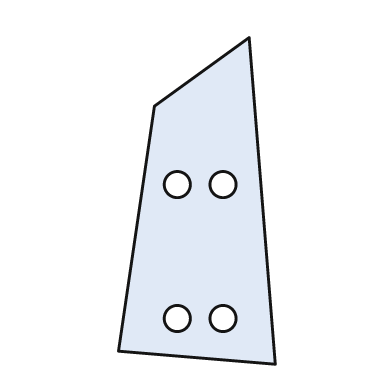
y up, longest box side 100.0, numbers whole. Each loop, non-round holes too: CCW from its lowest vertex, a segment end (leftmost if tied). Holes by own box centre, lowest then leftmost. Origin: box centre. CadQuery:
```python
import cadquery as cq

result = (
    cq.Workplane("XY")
    .moveTo(24.0, -50.0)
    .lineTo(16.0, 50.0)
    .lineTo(-13.0, 29.0)
    .lineTo(-24.0, -46.0)
    .close()
    .moveTo(-6.0, -36.0)
    .circle(4.0)
    .moveTo(8.0, -36.0)
    .circle(4.0)
    .moveTo(-6.0, 5.0)
    .circle(4.0)
    .moveTo(8.0, 5.0)
    .circle(4.0)
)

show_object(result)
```